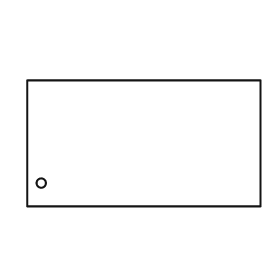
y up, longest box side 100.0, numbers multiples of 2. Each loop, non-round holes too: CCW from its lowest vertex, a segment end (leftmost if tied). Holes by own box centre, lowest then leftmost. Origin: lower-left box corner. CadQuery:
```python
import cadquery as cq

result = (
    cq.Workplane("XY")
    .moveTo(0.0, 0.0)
    .lineTo(100.0, 0.0)
    .lineTo(100.0, 54.0)
    .lineTo(0.0, 54.0)
    .close()
    .moveTo(6.0, 10.0)
    .circle(2.0)
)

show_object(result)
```